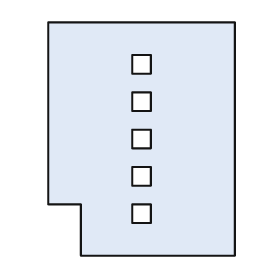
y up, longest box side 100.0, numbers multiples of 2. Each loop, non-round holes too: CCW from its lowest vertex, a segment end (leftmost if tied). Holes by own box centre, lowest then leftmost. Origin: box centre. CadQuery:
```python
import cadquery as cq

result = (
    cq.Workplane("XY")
    .moveTo(-26.0, -50.0)
    .lineTo(40.0, -50.0)
    .lineTo(40.0, 50.0)
    .lineTo(-40.0, 50.0)
    .lineTo(-40.0, -28.0)
    .lineTo(-26.0, -28.0)
    .close()
    .moveTo(-4.0, -36.0)
    .lineTo(4.0, -36.0)
    .lineTo(4.0, -28.0)
    .lineTo(-4.0, -28.0)
    .close()
    .moveTo(-4.0, -20.0)
    .lineTo(4.0, -20.0)
    .lineTo(4.0, -12.0)
    .lineTo(-4.0, -12.0)
    .close()
    .moveTo(-4.0, -4.0)
    .lineTo(4.0, -4.0)
    .lineTo(4.0, 4.0)
    .lineTo(-4.0, 4.0)
    .close()
    .moveTo(-4.0, 12.0)
    .lineTo(4.0, 12.0)
    .lineTo(4.0, 20.0)
    .lineTo(-4.0, 20.0)
    .close()
    .moveTo(-4.0, 28.0)
    .lineTo(4.0, 28.0)
    .lineTo(4.0, 36.0)
    .lineTo(-4.0, 36.0)
    .close()
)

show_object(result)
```